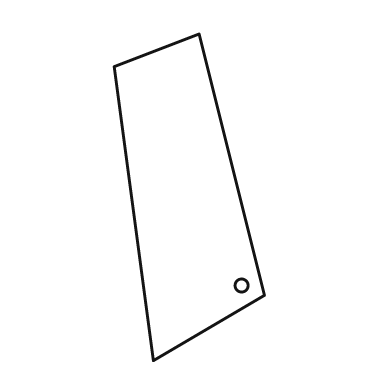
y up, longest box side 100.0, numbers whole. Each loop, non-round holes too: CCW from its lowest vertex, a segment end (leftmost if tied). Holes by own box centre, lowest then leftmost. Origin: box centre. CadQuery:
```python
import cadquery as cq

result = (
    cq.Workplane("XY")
    .moveTo(-11.0, -50.0)
    .lineTo(23.0, -30.0)
    .lineTo(3.0, 50.0)
    .lineTo(-23.0, 40.0)
    .close()
    .moveTo(16.0, -27.0)
    .circle(2.0)
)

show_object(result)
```